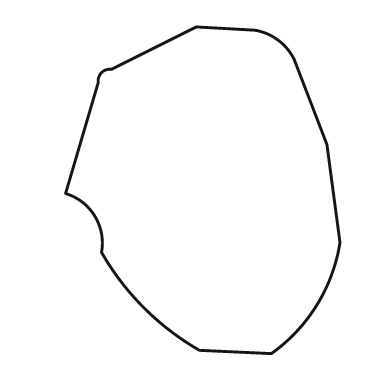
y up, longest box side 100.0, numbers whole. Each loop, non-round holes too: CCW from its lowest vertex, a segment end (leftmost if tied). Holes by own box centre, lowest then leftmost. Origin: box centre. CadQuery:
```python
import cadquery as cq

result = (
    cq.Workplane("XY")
    .moveTo(21.0, -50.0)
    .threePointArc((35.0, -35.0), (42.0, -16.0))
    .lineTo(38.0, 14.0)
    .lineTo(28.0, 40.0)
    .threePointArc((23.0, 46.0), (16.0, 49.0))
    .lineTo(-2.0, 50.0)
    .lineTo(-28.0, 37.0)
    .threePointArc((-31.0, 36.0), (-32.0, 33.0))
    .lineTo(-42.0, -1.0)
    .threePointArc((-33.0, -8.0), (-31.0, -19.0))
    .threePointArc((-18.0, -36.0), (-1.0, -49.0))
    .close()
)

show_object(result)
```